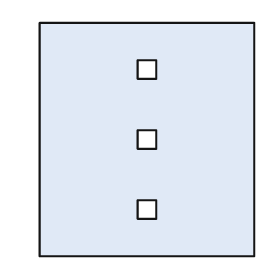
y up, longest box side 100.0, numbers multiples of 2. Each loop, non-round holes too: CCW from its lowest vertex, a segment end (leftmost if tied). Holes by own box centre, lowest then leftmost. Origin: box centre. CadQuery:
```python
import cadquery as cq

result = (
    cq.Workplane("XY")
    .moveTo(-46.0, -50.0)
    .lineTo(46.0, -50.0)
    .lineTo(46.0, 50.0)
    .lineTo(-46.0, 50.0)
    .close()
    .moveTo(-4.0, -34.0)
    .lineTo(4.0, -34.0)
    .lineTo(4.0, -26.0)
    .lineTo(-4.0, -26.0)
    .close()
    .moveTo(-4.0, -4.0)
    .lineTo(4.0, -4.0)
    .lineTo(4.0, 4.0)
    .lineTo(-4.0, 4.0)
    .close()
    .moveTo(-4.0, 26.0)
    .lineTo(4.0, 26.0)
    .lineTo(4.0, 34.0)
    .lineTo(-4.0, 34.0)
    .close()
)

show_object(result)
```